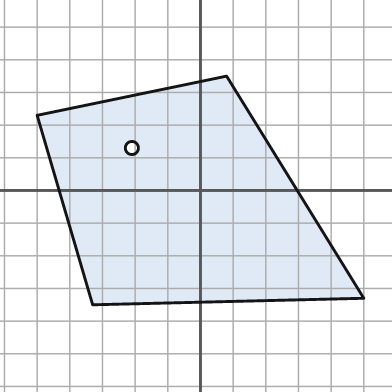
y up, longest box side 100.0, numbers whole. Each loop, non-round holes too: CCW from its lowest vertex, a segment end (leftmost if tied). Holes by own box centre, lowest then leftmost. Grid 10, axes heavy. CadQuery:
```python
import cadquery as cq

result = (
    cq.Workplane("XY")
    .moveTo(-33.0, -35.0)
    .lineTo(50.0, -33.0)
    .lineTo(8.0, 35.0)
    .lineTo(-50.0, 23.0)
    .close()
    .moveTo(-21.0, 13.0)
    .circle(2.0)
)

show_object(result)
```